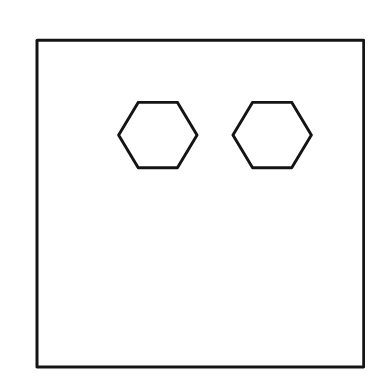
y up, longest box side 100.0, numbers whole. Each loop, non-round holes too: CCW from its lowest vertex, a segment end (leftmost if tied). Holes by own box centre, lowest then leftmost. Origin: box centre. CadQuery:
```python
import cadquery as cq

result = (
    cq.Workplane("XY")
    .moveTo(-50.0, -50.0)
    .lineTo(50.0, -50.0)
    .lineTo(50.0, 50.0)
    .lineTo(-50.0, 50.0)
    .close()
    .moveTo(-19.0, 11.0)
    .lineTo(-7.0, 11.0)
    .lineTo(-1.0, 21.0)
    .lineTo(-7.0, 31.0)
    .lineTo(-19.0, 31.0)
    .lineTo(-25.0, 21.0)
    .close()
    .moveTo(16.0, 11.0)
    .lineTo(28.0, 11.0)
    .lineTo(34.0, 21.0)
    .lineTo(28.0, 31.0)
    .lineTo(16.0, 31.0)
    .lineTo(10.0, 21.0)
    .close()
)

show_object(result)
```